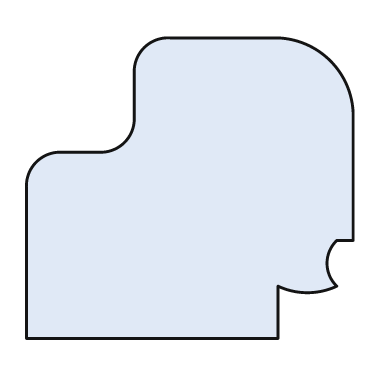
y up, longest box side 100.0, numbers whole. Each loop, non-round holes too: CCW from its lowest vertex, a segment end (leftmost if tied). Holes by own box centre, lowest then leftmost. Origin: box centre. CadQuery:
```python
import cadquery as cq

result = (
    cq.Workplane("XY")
    .moveTo(-50.0, -46.0)
    .lineTo(27.0, -46.0)
    .lineTo(27.0, -30.0)
    .threePointArc((36.0, -32.0), (45.0, -30.0))
    .threePointArc((42.0, -23.0), (45.0, -16.0))
    .lineTo(50.0, -16.0)
    .lineTo(50.0, 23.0)
    .threePointArc((43.0, 39.0), (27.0, 46.0))
    .lineTo(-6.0, 46.0)
    .threePointArc((-14.0, 43.0), (-17.0, 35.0))
    .lineTo(-17.0, 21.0)
    .threePointArc((-20.0, 14.0), (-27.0, 11.0))
    .lineTo(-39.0, 11.0)
    .threePointArc((-47.0, 8.0), (-50.0, 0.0))
    .close()
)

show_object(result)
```